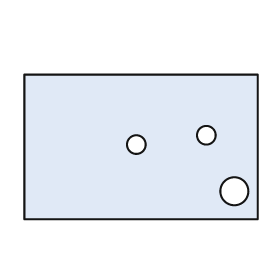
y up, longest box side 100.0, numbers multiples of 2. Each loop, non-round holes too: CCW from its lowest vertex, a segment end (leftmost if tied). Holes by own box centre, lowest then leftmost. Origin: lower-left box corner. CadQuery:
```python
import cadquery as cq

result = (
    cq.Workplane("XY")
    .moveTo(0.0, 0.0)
    .lineTo(100.0, 0.0)
    .lineTo(100.0, 62.0)
    .lineTo(0.0, 62.0)
    .close()
    .moveTo(90.0, 12.0)
    .circle(6.0)
    .moveTo(48.0, 32.0)
    .circle(4.0)
    .moveTo(78.0, 36.0)
    .circle(4.0)
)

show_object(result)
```